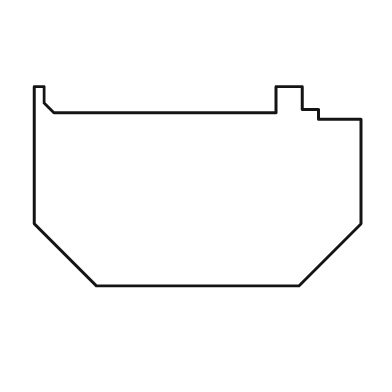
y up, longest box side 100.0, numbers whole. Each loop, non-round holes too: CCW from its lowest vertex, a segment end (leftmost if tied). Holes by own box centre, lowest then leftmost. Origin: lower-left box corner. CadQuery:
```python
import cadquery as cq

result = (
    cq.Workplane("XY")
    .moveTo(19.0, 0.0)
    .lineTo(81.0, 0.0)
    .lineTo(100.0, 19.0)
    .lineTo(100.0, 51.0)
    .lineTo(87.0, 51.0)
    .lineTo(87.0, 54.0)
    .lineTo(82.0, 54.0)
    .lineTo(82.0, 61.0)
    .lineTo(74.0, 61.0)
    .lineTo(74.0, 53.0)
    .lineTo(6.0, 53.0)
    .lineTo(3.0, 56.0)
    .lineTo(3.0, 61.0)
    .lineTo(0.0, 61.0)
    .lineTo(0.0, 19.0)
    .close()
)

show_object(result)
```